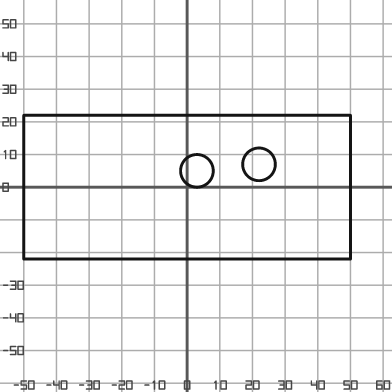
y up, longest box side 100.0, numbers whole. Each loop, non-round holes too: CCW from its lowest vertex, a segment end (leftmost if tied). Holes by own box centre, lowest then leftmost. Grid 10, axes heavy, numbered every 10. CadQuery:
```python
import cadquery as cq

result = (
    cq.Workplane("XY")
    .moveTo(-50.0, -22.0)
    .lineTo(50.0, -22.0)
    .lineTo(50.0, 22.0)
    .lineTo(-50.0, 22.0)
    .close()
    .moveTo(3.0, 5.0)
    .circle(5.0)
    .moveTo(22.0, 7.0)
    .circle(5.0)
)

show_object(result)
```